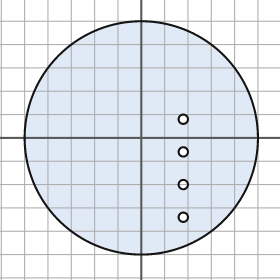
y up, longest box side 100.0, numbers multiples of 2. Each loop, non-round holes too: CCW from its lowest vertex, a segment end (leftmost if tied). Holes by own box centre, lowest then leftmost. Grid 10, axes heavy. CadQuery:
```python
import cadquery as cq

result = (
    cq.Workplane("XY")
    .moveTo(0.0, 0.0)
    .circle(50.0)
    .moveTo(18.0, -34.0)
    .circle(2.0)
    .moveTo(18.0, -20.0)
    .circle(2.0)
    .moveTo(18.0, -6.0)
    .circle(2.0)
    .moveTo(18.0, 8.0)
    .circle(2.0)
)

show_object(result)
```